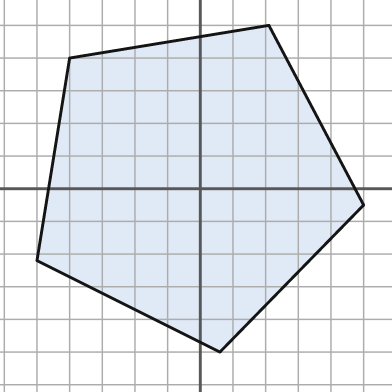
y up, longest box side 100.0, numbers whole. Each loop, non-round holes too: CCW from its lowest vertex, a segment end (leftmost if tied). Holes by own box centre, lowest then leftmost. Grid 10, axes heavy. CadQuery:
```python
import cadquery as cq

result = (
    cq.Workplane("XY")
    .moveTo(6.0, -50.0)
    .lineTo(50.0, -5.0)
    .lineTo(21.0, 50.0)
    .lineTo(-40.0, 40.0)
    .lineTo(-50.0, -22.0)
    .close()
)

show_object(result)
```